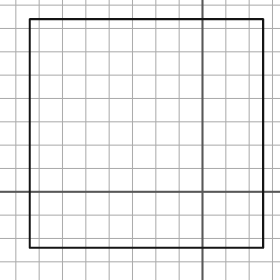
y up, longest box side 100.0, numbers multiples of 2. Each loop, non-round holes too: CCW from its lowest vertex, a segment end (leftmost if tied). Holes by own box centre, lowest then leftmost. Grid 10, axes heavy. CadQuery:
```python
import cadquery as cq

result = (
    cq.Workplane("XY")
    .moveTo(-74.0, -24.0)
    .lineTo(26.0, -24.0)
    .lineTo(26.0, 74.0)
    .lineTo(-74.0, 74.0)
    .close()
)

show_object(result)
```